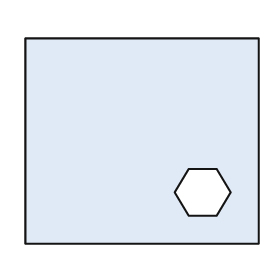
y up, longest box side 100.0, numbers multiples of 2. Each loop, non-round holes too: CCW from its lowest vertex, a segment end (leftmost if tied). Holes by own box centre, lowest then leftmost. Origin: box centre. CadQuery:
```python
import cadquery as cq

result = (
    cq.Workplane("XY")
    .moveTo(-50.0, -44.0)
    .lineTo(50.0, -44.0)
    .lineTo(50.0, 44.0)
    .lineTo(-50.0, 44.0)
    .close()
    .moveTo(20.0, -32.0)
    .lineTo(32.0, -32.0)
    .lineTo(38.0, -22.0)
    .lineTo(32.0, -12.0)
    .lineTo(20.0, -12.0)
    .lineTo(14.0, -22.0)
    .close()
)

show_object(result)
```